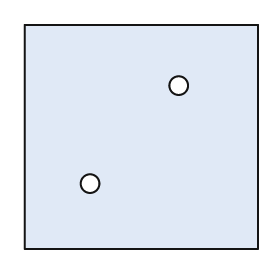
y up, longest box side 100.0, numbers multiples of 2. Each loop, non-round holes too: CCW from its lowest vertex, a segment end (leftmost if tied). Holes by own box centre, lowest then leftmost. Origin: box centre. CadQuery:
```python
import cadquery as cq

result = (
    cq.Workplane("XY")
    .moveTo(-50.0, -48.0)
    .lineTo(50.0, -48.0)
    .lineTo(50.0, 48.0)
    .lineTo(-50.0, 48.0)
    .close()
    .moveTo(-22.0, -20.0)
    .circle(4.0)
    .moveTo(16.0, 22.0)
    .circle(4.0)
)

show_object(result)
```